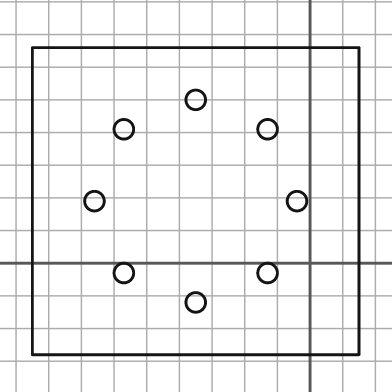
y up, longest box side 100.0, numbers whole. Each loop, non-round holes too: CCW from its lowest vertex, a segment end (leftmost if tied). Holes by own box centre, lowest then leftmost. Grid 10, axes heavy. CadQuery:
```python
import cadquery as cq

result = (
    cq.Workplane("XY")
    .moveTo(-85.0, -28.0)
    .lineTo(15.0, -28.0)
    .lineTo(15.0, 66.0)
    .lineTo(-85.0, 66.0)
    .close()
    .moveTo(-35.0, -12.0)
    .circle(3.0)
    .moveTo(-57.0, -3.0)
    .circle(3.0)
    .moveTo(-13.0, -3.0)
    .circle(3.0)
    .moveTo(-66.0, 19.0)
    .circle(3.0)
    .moveTo(-4.0, 19.0)
    .circle(3.0)
    .moveTo(-57.0, 41.0)
    .circle(3.0)
    .moveTo(-13.0, 41.0)
    .circle(3.0)
    .moveTo(-35.0, 50.0)
    .circle(3.0)
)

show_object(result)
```